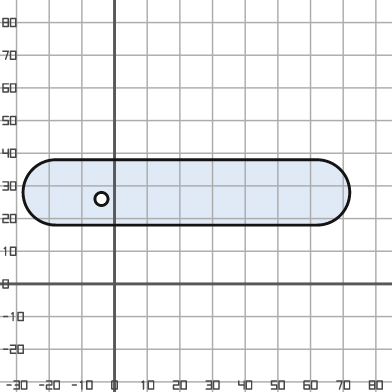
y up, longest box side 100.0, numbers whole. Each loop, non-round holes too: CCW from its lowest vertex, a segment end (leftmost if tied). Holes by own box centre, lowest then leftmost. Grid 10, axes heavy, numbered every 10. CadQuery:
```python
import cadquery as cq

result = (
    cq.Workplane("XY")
    .moveTo(-18.0, 18.0)
    .lineTo(62.0, 18.0)
    .threePointArc((72.0, 28.0), (62.0, 38.0))
    .lineTo(-18.0, 38.0)
    .threePointArc((-28.0, 28.0), (-18.0, 18.0))
    .close()
    .moveTo(-4.0, 26.0)
    .circle(2.0)
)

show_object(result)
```